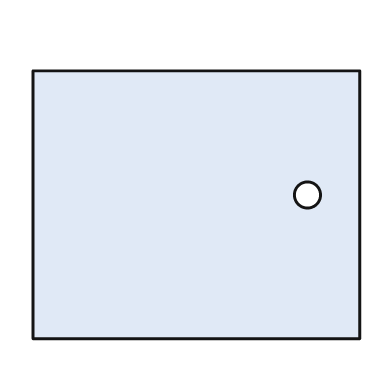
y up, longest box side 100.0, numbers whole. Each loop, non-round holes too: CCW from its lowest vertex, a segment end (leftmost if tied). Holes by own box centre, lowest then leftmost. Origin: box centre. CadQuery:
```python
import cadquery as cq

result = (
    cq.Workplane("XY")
    .moveTo(-50.0, -41.0)
    .lineTo(50.0, -41.0)
    .lineTo(50.0, 41.0)
    .lineTo(-50.0, 41.0)
    .close()
    .moveTo(34.0, 3.0)
    .circle(4.0)
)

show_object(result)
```